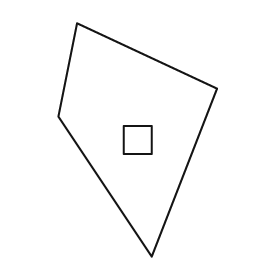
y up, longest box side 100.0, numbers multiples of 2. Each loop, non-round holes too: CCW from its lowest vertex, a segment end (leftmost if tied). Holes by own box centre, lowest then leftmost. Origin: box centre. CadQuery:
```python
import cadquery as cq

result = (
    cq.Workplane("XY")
    .moveTo(6.0, -50.0)
    .lineTo(34.0, 22.0)
    .lineTo(-26.0, 50.0)
    .lineTo(-34.0, 10.0)
    .close()
    .moveTo(-6.0, -6.0)
    .lineTo(6.0, -6.0)
    .lineTo(6.0, 6.0)
    .lineTo(-6.0, 6.0)
    .close()
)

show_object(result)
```